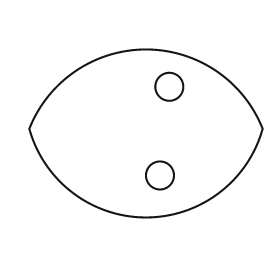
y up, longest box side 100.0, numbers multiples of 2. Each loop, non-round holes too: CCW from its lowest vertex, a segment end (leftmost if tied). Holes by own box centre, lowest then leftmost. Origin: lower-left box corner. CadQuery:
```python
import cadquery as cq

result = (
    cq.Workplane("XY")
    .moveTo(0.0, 38.0)
    .threePointArc((50.0, 0.0), (100.0, 38.0))
    .threePointArc((50.0, 72.0), (0.0, 38.0))
    .close()
    .moveTo(56.0, 18.0)
    .circle(6.0)
    .moveTo(60.0, 56.0)
    .circle(6.0)
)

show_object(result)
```